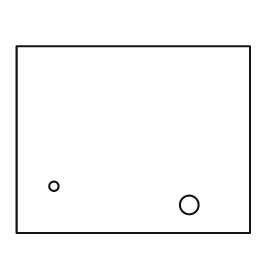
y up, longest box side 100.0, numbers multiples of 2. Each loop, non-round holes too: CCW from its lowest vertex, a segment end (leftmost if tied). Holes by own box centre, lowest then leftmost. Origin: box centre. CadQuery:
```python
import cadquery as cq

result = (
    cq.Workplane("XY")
    .moveTo(-50.0, -40.0)
    .lineTo(50.0, -40.0)
    .lineTo(50.0, 40.0)
    .lineTo(-50.0, 40.0)
    .close()
    .moveTo(24.0, -28.0)
    .circle(4.0)
    .moveTo(-34.0, -20.0)
    .circle(2.0)
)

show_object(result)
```